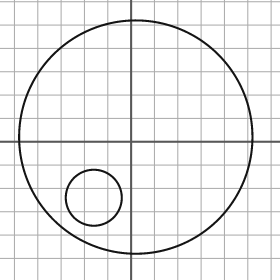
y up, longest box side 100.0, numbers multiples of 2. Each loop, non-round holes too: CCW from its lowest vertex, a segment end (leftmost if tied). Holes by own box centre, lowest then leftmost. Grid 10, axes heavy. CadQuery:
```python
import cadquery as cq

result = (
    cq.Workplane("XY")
    .moveTo(2.0, 2.0)
    .circle(50.0)
    .moveTo(-16.0, -24.0)
    .circle(12.0)
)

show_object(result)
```